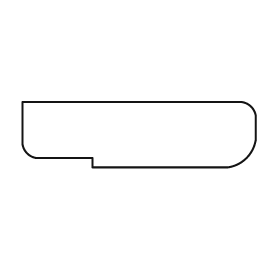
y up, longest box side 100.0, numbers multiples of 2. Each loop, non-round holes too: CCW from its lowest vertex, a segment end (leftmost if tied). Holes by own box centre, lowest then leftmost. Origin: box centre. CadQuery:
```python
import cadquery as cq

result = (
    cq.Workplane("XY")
    .moveTo(-20.0, -14.0)
    .lineTo(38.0, -14.0)
    .threePointArc((46.0, -10.0), (50.0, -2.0))
    .lineTo(50.0, 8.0)
    .threePointArc((48.0, 12.0), (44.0, 14.0))
    .lineTo(-50.0, 14.0)
    .lineTo(-50.0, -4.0)
    .threePointArc((-48.0, -8.0), (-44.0, -10.0))
    .lineTo(-20.0, -10.0)
    .close()
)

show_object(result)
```